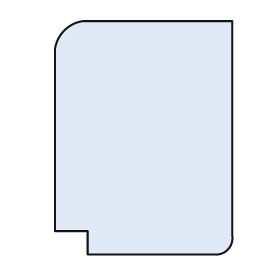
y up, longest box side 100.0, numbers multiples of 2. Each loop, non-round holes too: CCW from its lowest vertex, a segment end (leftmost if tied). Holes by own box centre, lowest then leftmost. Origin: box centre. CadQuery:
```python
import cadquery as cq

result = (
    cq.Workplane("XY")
    .moveTo(-24.0, -50.0)
    .lineTo(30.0, -50.0)
    .threePointArc((36.0, -48.0), (38.0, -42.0))
    .lineTo(38.0, 50.0)
    .lineTo(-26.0, 50.0)
    .threePointArc((-34.0, 46.0), (-38.0, 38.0))
    .lineTo(-38.0, -40.0)
    .lineTo(-24.0, -40.0)
    .close()
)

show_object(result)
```